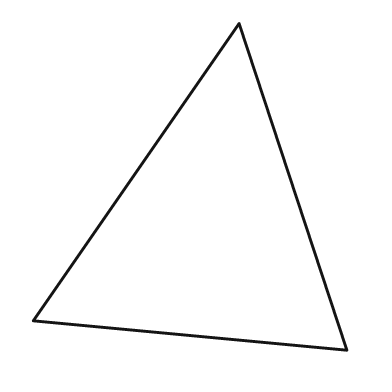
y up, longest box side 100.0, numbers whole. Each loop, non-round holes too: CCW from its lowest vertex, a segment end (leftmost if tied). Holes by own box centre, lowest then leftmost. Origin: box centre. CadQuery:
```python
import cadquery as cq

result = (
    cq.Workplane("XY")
    .moveTo(48.0, -50.0)
    .lineTo(15.0, 50.0)
    .lineTo(-48.0, -41.0)
    .close()
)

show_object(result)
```